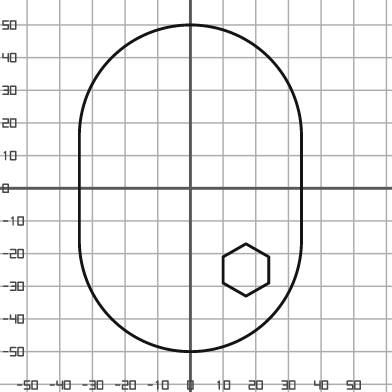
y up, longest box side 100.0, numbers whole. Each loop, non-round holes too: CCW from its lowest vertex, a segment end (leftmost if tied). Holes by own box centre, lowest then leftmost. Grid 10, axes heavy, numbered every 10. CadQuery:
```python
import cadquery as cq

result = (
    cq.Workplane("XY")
    .moveTo(-34.0, -16.0)
    .threePointArc((0.0, -50.0), (34.0, -16.0))
    .lineTo(34.0, 16.0)
    .threePointArc((0.0, 50.0), (-34.0, 16.0))
    .close()
    .moveTo(17.0, -33.0)
    .lineTo(24.0, -29.0)
    .lineTo(24.0, -21.0)
    .lineTo(17.0, -17.0)
    .lineTo(10.0, -21.0)
    .lineTo(10.0, -29.0)
    .close()
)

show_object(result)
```